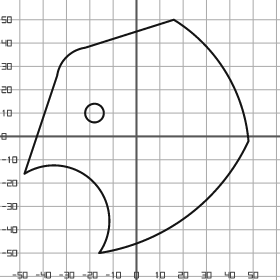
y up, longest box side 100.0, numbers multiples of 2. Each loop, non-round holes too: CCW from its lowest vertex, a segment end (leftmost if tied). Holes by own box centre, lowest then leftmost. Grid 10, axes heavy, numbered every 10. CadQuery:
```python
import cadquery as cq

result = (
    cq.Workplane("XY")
    .moveTo(-16.0, -50.0)
    .threePointArc((22.0, -34.0), (48.0, -2.0))
    .threePointArc((38.0, 28.0), (16.0, 50.0))
    .lineTo(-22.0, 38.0)
    .threePointArc((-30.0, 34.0), (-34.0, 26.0))
    .lineTo(-48.0, -16.0)
    .threePointArc((-18.0, -20.0), (-16.0, -50.0))
    .close()
    .moveTo(-18.0, 10.0)
    .circle(4.0)
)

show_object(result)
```